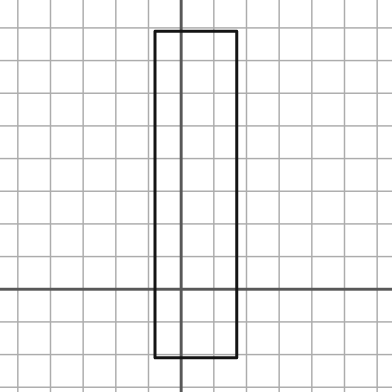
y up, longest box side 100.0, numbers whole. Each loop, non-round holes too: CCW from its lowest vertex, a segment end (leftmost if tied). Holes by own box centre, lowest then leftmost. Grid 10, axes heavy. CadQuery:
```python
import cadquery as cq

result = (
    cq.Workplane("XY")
    .moveTo(-8.0, -21.0)
    .lineTo(17.0, -21.0)
    .lineTo(17.0, 79.0)
    .lineTo(-8.0, 79.0)
    .close()
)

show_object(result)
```